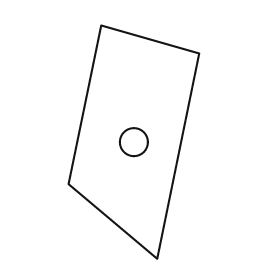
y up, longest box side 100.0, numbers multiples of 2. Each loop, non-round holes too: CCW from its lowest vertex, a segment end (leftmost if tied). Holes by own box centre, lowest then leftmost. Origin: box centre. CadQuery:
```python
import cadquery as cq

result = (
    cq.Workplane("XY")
    .moveTo(10.0, -50.0)
    .lineTo(28.0, 38.0)
    .lineTo(-14.0, 50.0)
    .lineTo(-28.0, -18.0)
    .close()
    .moveTo(0.0, 0.0)
    .circle(6.0)
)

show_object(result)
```